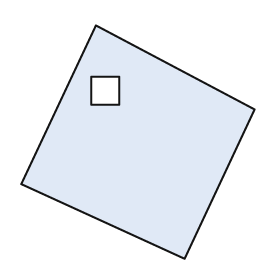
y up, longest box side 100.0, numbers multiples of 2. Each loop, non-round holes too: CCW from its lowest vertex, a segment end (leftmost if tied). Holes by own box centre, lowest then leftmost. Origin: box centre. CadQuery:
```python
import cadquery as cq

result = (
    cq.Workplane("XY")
    .moveTo(20.0, -50.0)
    .lineTo(50.0, 14.0)
    .lineTo(-18.0, 50.0)
    .lineTo(-50.0, -18.0)
    .close()
    .moveTo(-20.0, 16.0)
    .lineTo(-8.0, 16.0)
    .lineTo(-8.0, 28.0)
    .lineTo(-20.0, 28.0)
    .close()
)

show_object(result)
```